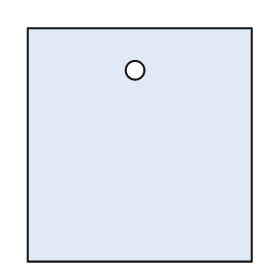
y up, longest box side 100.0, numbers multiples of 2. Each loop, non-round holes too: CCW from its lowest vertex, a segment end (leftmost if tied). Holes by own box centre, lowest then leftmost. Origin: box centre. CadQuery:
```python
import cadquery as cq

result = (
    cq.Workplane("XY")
    .moveTo(-48.0, -50.0)
    .lineTo(48.0, -50.0)
    .lineTo(48.0, 50.0)
    .lineTo(-48.0, 50.0)
    .close()
    .moveTo(-2.0, 32.0)
    .circle(4.0)
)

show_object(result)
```